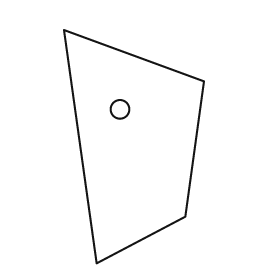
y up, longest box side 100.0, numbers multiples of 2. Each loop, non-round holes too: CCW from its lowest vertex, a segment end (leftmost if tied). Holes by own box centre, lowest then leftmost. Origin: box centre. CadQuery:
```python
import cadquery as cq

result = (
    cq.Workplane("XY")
    .moveTo(-16.0, -50.0)
    .lineTo(22.0, -30.0)
    .lineTo(30.0, 28.0)
    .lineTo(-30.0, 50.0)
    .close()
    .moveTo(-6.0, 16.0)
    .circle(4.0)
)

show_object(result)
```